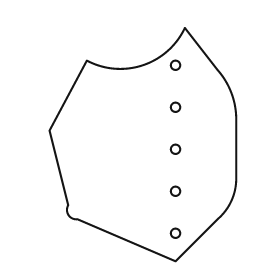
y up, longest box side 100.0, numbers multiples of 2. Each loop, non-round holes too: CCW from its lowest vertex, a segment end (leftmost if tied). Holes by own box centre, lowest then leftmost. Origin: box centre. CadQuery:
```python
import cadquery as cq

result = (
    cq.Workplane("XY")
    .moveTo(14.0, -50.0)
    .lineTo(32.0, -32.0)
    .threePointArc((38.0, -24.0), (40.0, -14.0))
    .lineTo(40.0, 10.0)
    .threePointArc((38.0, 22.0), (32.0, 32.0))
    .lineTo(18.0, 50.0)
    .threePointArc((0.0, 34.0), (-24.0, 36.0))
    .lineTo(-40.0, 6.0)
    .lineTo(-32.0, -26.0)
    .threePointArc((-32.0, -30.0), (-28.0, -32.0))
    .close()
    .moveTo(14.0, -38.0)
    .circle(2.0)
    .moveTo(14.0, -20.0)
    .circle(2.0)
    .moveTo(14.0, -2.0)
    .circle(2.0)
    .moveTo(14.0, 16.0)
    .circle(2.0)
    .moveTo(14.0, 34.0)
    .circle(2.0)
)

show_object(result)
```